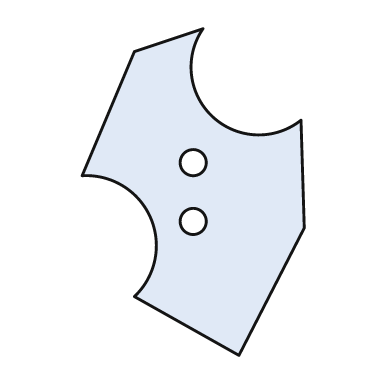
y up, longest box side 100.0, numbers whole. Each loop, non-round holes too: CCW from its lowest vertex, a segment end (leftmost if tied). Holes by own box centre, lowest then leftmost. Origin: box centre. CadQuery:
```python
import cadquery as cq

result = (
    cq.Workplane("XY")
    .moveTo(14.0, -50.0)
    .lineTo(34.0, -11.0)
    .lineTo(33.0, 22.0)
    .threePointArc((6.0, 23.0), (3.0, 50.0))
    .lineTo(-18.0, 43.0)
    .lineTo(-34.0, 5.0)
    .threePointArc((-13.0, -8.0), (-18.0, -32.0))
    .close()
    .moveTo(0.0, -9.0)
    .circle(4.0)
    .moveTo(0.0, 9.0)
    .circle(4.0)
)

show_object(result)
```